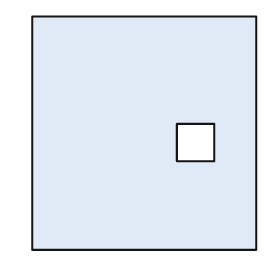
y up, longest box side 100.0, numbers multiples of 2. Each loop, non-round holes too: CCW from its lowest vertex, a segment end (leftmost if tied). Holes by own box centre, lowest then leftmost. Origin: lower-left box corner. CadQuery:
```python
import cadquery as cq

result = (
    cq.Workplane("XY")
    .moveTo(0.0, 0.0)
    .lineTo(96.0, 0.0)
    .lineTo(96.0, 100.0)
    .lineTo(0.0, 100.0)
    .close()
    .moveTo(62.0, 38.0)
    .lineTo(78.0, 38.0)
    .lineTo(78.0, 54.0)
    .lineTo(62.0, 54.0)
    .close()
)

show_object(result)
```